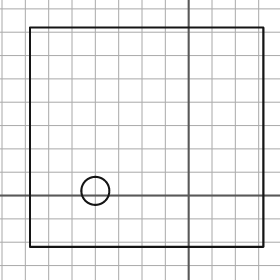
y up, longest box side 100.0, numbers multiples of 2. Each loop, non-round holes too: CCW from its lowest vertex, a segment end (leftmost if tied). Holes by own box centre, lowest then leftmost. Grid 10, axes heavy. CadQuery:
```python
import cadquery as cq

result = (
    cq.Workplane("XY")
    .moveTo(-68.0, -22.0)
    .lineTo(32.0, -22.0)
    .lineTo(32.0, 72.0)
    .lineTo(-68.0, 72.0)
    .close()
    .moveTo(-40.0, 2.0)
    .circle(6.0)
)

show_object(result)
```